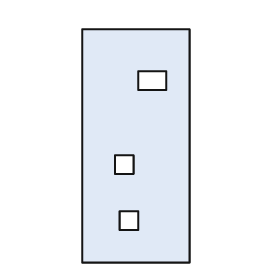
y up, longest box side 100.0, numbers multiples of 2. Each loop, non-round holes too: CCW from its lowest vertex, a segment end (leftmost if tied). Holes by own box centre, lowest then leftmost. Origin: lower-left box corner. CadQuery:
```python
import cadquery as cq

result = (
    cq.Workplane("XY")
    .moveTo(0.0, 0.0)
    .lineTo(46.0, 0.0)
    .lineTo(46.0, 100.0)
    .lineTo(0.0, 100.0)
    .close()
    .moveTo(16.0, 14.0)
    .lineTo(24.0, 14.0)
    .lineTo(24.0, 22.0)
    .lineTo(16.0, 22.0)
    .close()
    .moveTo(14.0, 38.0)
    .lineTo(22.0, 38.0)
    .lineTo(22.0, 46.0)
    .lineTo(14.0, 46.0)
    .close()
    .moveTo(24.0, 74.0)
    .lineTo(36.0, 74.0)
    .lineTo(36.0, 82.0)
    .lineTo(24.0, 82.0)
    .close()
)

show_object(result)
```